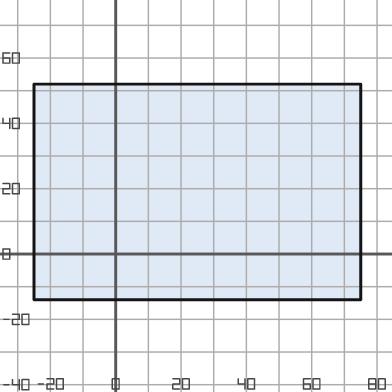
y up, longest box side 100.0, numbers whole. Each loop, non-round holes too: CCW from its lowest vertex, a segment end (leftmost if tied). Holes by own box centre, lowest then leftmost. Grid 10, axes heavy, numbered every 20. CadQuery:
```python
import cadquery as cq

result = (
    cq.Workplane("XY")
    .moveTo(-25.0, -14.0)
    .lineTo(75.0, -14.0)
    .lineTo(75.0, 52.0)
    .lineTo(-25.0, 52.0)
    .close()
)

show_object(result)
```